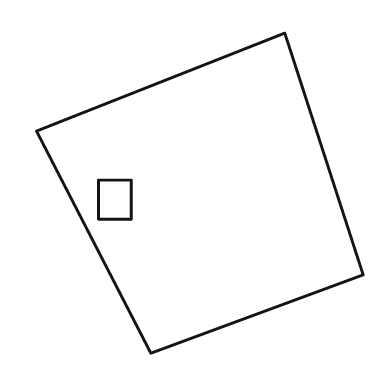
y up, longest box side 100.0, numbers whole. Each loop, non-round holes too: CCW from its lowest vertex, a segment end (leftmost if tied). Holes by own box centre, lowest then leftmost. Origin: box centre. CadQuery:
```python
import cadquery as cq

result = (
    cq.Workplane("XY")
    .moveTo(-15.0, -49.0)
    .lineTo(50.0, -25.0)
    .lineTo(26.0, 49.0)
    .lineTo(-50.0, 19.0)
    .close()
    .moveTo(-31.0, -8.0)
    .lineTo(-21.0, -8.0)
    .lineTo(-21.0, 4.0)
    .lineTo(-31.0, 4.0)
    .close()
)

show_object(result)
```